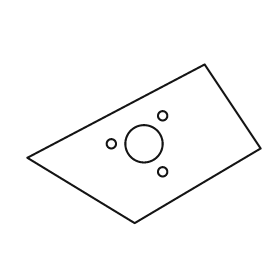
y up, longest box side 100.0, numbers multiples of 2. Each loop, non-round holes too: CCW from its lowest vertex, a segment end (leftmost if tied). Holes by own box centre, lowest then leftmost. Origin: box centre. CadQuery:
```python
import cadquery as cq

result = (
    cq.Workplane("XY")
    .moveTo(-4.0, -34.0)
    .lineTo(50.0, -2.0)
    .lineTo(26.0, 34.0)
    .lineTo(-50.0, -6.0)
    .close()
    .moveTo(8.0, -12.0)
    .circle(2.0)
    .moveTo(-14.0, 0.0)
    .circle(2.0)
    .moveTo(0.0, 0.0)
    .circle(8.0)
    .moveTo(8.0, 12.0)
    .circle(2.0)
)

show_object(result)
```